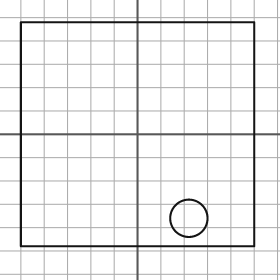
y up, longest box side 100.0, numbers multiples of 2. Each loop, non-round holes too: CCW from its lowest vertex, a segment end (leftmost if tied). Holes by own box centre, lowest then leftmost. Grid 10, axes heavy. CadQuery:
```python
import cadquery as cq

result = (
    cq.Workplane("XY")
    .moveTo(-50.0, -48.0)
    .lineTo(50.0, -48.0)
    .lineTo(50.0, 48.0)
    .lineTo(-50.0, 48.0)
    .close()
    .moveTo(22.0, -36.0)
    .circle(8.0)
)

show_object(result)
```